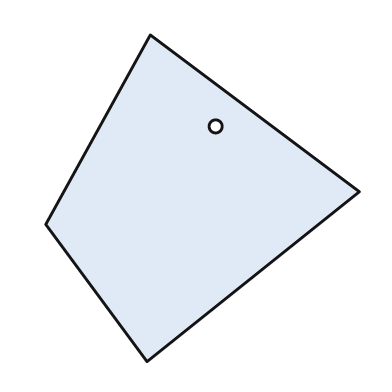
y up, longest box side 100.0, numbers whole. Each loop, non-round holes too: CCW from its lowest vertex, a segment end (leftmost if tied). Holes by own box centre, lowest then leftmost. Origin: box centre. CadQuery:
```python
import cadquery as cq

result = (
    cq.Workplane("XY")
    .moveTo(-17.0, -50.0)
    .lineTo(48.0, 2.0)
    .lineTo(-16.0, 50.0)
    .lineTo(-48.0, -8.0)
    .close()
    .moveTo(4.0, 22.0)
    .circle(2.0)
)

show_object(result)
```